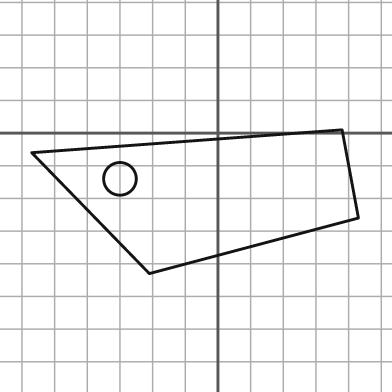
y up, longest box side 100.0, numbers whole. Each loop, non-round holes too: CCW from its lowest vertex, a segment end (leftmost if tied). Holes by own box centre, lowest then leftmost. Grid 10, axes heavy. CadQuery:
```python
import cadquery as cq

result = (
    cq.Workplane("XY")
    .moveTo(-21.0, -43.0)
    .lineTo(43.0, -26.0)
    .lineTo(38.0, 1.0)
    .lineTo(-57.0, -6.0)
    .close()
    .moveTo(-30.0, -14.0)
    .circle(5.0)
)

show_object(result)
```